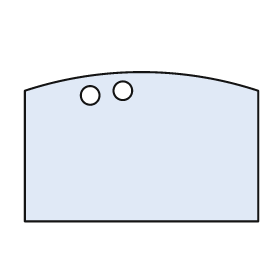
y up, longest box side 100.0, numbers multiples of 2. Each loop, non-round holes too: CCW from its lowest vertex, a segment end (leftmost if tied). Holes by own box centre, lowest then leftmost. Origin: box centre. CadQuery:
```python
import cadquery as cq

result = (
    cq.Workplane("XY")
    .moveTo(-50.0, -32.0)
    .lineTo(50.0, -32.0)
    .lineTo(50.0, 24.0)
    .threePointArc((0.0, 32.0), (-50.0, 24.0))
    .close()
    .moveTo(-22.0, 22.0)
    .circle(4.0)
    .moveTo(-8.0, 24.0)
    .circle(4.0)
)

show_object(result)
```